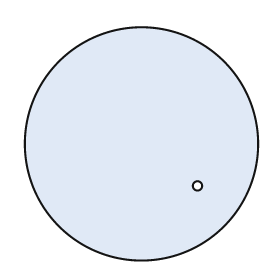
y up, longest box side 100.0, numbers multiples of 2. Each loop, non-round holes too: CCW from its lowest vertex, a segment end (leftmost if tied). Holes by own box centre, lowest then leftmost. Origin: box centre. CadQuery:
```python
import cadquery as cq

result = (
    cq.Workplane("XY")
    .moveTo(0.0, 0.0)
    .circle(50.0)
    .moveTo(24.0, -18.0)
    .circle(2.0)
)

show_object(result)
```